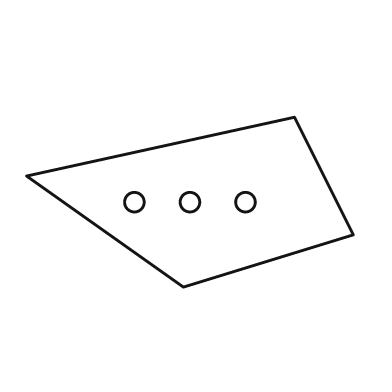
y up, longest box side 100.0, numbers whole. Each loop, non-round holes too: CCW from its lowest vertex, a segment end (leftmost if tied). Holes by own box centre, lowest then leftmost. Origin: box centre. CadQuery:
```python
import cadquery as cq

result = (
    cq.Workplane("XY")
    .moveTo(-2.0, -26.0)
    .lineTo(50.0, -10.0)
    .lineTo(32.0, 26.0)
    .lineTo(-50.0, 8.0)
    .close()
    .moveTo(-17.0, 0.0)
    .circle(3.0)
    .moveTo(0.0, 0.0)
    .circle(3.0)
    .moveTo(17.0, 0.0)
    .circle(3.0)
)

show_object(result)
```